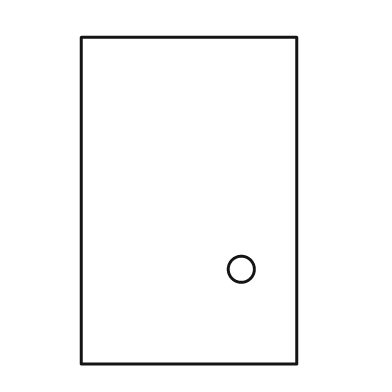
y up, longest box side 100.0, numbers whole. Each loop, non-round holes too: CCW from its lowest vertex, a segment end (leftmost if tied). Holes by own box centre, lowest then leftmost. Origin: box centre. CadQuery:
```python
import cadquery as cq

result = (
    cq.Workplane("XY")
    .moveTo(-33.0, -50.0)
    .lineTo(33.0, -50.0)
    .lineTo(33.0, 50.0)
    .lineTo(-33.0, 50.0)
    .close()
    .moveTo(16.0, -21.0)
    .circle(4.0)
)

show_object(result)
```